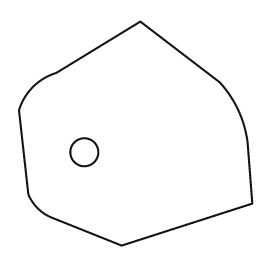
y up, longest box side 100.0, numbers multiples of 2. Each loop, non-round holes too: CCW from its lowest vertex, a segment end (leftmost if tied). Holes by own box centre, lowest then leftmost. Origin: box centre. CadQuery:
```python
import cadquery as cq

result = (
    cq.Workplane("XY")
    .moveTo(-6.0, -48.0)
    .lineTo(50.0, -30.0)
    .lineTo(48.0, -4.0)
    .threePointArc((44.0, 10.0), (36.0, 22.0))
    .lineTo(2.0, 48.0)
    .lineTo(-34.0, 26.0)
    .threePointArc((-44.0, 20.0), (-50.0, 10.0))
    .lineTo(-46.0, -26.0)
    .threePointArc((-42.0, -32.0), (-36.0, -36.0))
    .close()
    .moveTo(-22.0, -8.0)
    .circle(6.0)
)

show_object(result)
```